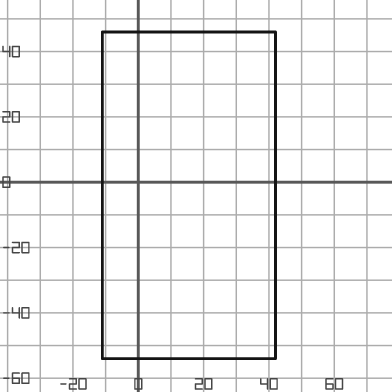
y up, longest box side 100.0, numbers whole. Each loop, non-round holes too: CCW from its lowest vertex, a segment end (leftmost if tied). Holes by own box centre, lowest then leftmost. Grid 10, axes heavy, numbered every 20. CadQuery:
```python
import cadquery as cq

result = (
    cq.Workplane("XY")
    .moveTo(-11.0, -54.0)
    .lineTo(42.0, -54.0)
    .lineTo(42.0, 46.0)
    .lineTo(-11.0, 46.0)
    .close()
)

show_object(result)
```